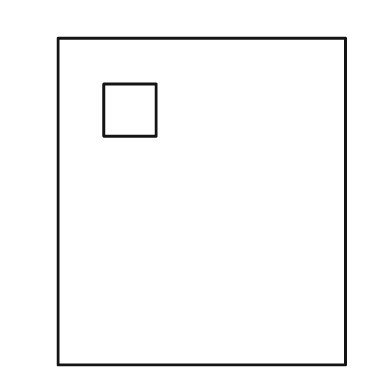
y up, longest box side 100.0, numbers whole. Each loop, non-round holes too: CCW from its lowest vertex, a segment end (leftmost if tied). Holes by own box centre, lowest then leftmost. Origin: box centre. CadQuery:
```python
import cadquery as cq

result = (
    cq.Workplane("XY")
    .moveTo(-44.0, -50.0)
    .lineTo(44.0, -50.0)
    .lineTo(44.0, 50.0)
    .lineTo(-44.0, 50.0)
    .close()
    .moveTo(-30.0, 20.0)
    .lineTo(-14.0, 20.0)
    .lineTo(-14.0, 36.0)
    .lineTo(-30.0, 36.0)
    .close()
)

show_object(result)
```